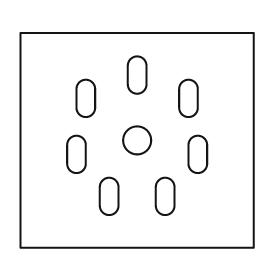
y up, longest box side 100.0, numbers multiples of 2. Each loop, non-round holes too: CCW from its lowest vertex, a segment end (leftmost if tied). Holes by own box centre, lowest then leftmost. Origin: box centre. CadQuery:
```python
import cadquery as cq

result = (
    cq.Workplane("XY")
    .moveTo(-50.0, -46.0)
    .lineTo(50.0, -46.0)
    .lineTo(50.0, 46.0)
    .lineTo(-50.0, 46.0)
    .close()
    .moveTo(-16.0, -28.0)
    .threePointArc((-12.0, -32.0), (-8.0, -28.0))
    .lineTo(-8.0, -20.0)
    .threePointArc((-12.0, -16.0), (-16.0, -20.0))
    .close()
    .moveTo(8.0, -28.0)
    .threePointArc((12.0, -32.0), (16.0, -28.0))
    .lineTo(16.0, -20.0)
    .threePointArc((12.0, -16.0), (8.0, -20.0))
    .close()
    .moveTo(-30.0, -10.0)
    .threePointArc((-26.0, -14.0), (-22.0, -10.0))
    .lineTo(-22.0, -2.0)
    .threePointArc((-26.0, 2.0), (-30.0, -2.0))
    .close()
    .moveTo(22.0, -10.0)
    .threePointArc((26.0, -14.0), (30.0, -10.0))
    .lineTo(30.0, -2.0)
    .threePointArc((26.0, 2.0), (22.0, -2.0))
    .close()
    .moveTo(0.0, 0.0)
    .circle(6.0)
    .moveTo(-26.0, 14.0)
    .threePointArc((-22.0, 10.0), (-18.0, 14.0))
    .lineTo(-18.0, 22.0)
    .threePointArc((-22.0, 26.0), (-26.0, 22.0))
    .close()
    .moveTo(18.0, 14.0)
    .threePointArc((22.0, 10.0), (26.0, 14.0))
    .lineTo(26.0, 22.0)
    .threePointArc((22.0, 26.0), (18.0, 22.0))
    .close()
    .moveTo(-4.0, 24.0)
    .threePointArc((0.0, 20.0), (4.0, 24.0))
    .lineTo(4.0, 32.0)
    .threePointArc((0.0, 36.0), (-4.0, 32.0))
    .close()
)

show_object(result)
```